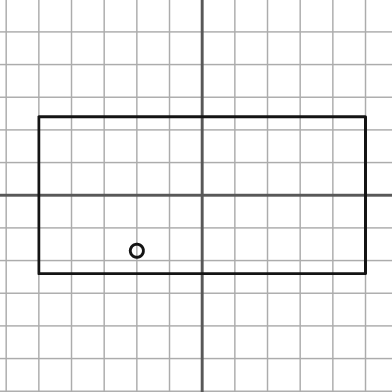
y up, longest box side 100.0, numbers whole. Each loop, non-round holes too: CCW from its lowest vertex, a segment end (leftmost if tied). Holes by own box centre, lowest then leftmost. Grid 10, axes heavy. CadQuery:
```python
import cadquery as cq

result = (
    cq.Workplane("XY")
    .moveTo(-50.0, -24.0)
    .lineTo(50.0, -24.0)
    .lineTo(50.0, 24.0)
    .lineTo(-50.0, 24.0)
    .close()
    .moveTo(-20.0, -17.0)
    .circle(2.0)
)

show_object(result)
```